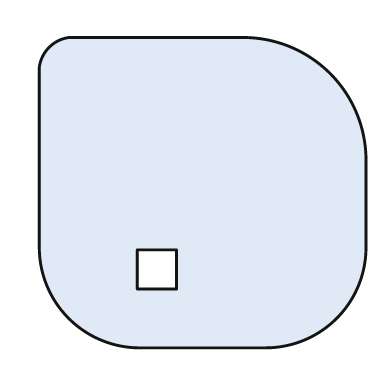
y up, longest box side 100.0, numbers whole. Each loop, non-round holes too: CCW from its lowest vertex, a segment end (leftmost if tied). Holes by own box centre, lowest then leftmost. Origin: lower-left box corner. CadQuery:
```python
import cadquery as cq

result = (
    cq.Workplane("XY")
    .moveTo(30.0, 0.0)
    .lineTo(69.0, 0.0)
    .threePointArc((91.0, 9.0), (100.0, 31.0))
    .lineTo(100.0, 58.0)
    .threePointArc((89.0, 84.0), (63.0, 95.0))
    .lineTo(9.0, 95.0)
    .threePointArc((3.0, 92.0), (0.0, 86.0))
    .lineTo(0.0, 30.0)
    .threePointArc((9.0, 9.0), (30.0, 0.0))
    .close()
    .moveTo(30.0, 18.0)
    .lineTo(42.0, 18.0)
    .lineTo(42.0, 30.0)
    .lineTo(30.0, 30.0)
    .close()
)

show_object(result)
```